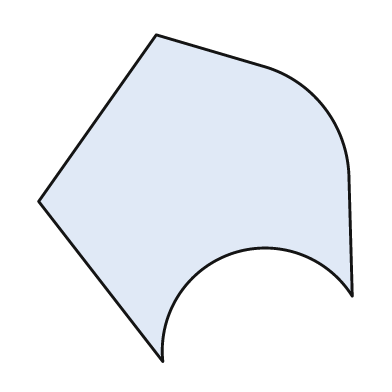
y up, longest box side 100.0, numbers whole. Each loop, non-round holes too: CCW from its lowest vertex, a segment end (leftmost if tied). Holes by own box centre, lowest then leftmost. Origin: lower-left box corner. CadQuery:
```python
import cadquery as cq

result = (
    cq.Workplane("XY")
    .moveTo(38.0, 0.0)
    .threePointArc((59.0, 33.0), (96.0, 20.0))
    .lineTo(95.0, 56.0)
    .threePointArc((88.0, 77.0), (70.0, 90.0))
    .lineTo(36.0, 100.0)
    .lineTo(0.0, 49.0)
    .close()
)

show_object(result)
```